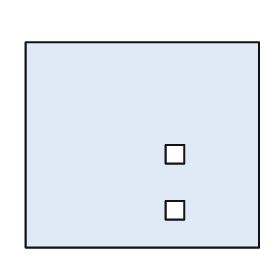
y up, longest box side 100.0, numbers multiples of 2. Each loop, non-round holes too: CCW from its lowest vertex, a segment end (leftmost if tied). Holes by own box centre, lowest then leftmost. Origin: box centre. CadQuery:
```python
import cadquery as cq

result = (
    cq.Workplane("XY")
    .moveTo(-50.0, -44.0)
    .lineTo(50.0, -44.0)
    .lineTo(50.0, 44.0)
    .lineTo(-50.0, 44.0)
    .close()
    .moveTo(10.0, -32.0)
    .lineTo(18.0, -32.0)
    .lineTo(18.0, -24.0)
    .lineTo(10.0, -24.0)
    .close()
    .moveTo(10.0, -8.0)
    .lineTo(18.0, -8.0)
    .lineTo(18.0, 0.0)
    .lineTo(10.0, 0.0)
    .close()
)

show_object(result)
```